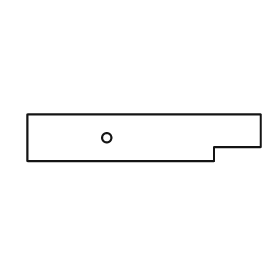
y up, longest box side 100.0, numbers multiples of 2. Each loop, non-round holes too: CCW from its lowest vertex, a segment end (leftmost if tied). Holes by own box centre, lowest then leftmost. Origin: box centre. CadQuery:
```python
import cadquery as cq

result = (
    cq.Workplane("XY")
    .moveTo(-50.0, -10.0)
    .lineTo(30.0, -10.0)
    .lineTo(30.0, -4.0)
    .lineTo(50.0, -4.0)
    .lineTo(50.0, 10.0)
    .lineTo(-50.0, 10.0)
    .close()
    .moveTo(-16.0, 0.0)
    .circle(2.0)
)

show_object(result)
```